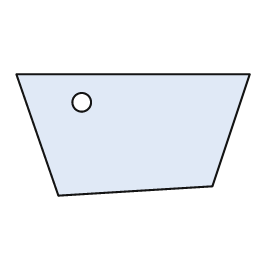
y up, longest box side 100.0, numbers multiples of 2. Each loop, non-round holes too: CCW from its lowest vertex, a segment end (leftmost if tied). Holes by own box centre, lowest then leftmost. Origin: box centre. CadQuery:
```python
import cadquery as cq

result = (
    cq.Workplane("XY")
    .moveTo(-32.0, -26.0)
    .lineTo(34.0, -22.0)
    .lineTo(50.0, 26.0)
    .lineTo(-50.0, 26.0)
    .close()
    .moveTo(-22.0, 14.0)
    .circle(4.0)
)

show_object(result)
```